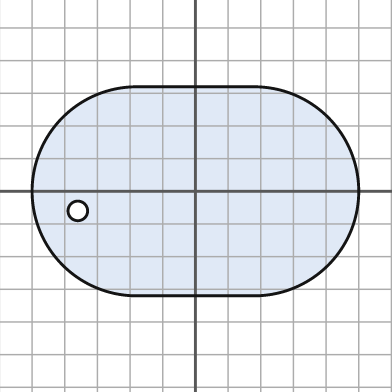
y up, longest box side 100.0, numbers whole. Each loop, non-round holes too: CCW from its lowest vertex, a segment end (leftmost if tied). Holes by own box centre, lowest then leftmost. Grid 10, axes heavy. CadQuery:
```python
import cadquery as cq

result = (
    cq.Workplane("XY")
    .moveTo(-18.0, -32.0)
    .lineTo(18.0, -32.0)
    .threePointArc((50.0, 0.0), (18.0, 32.0))
    .lineTo(-18.0, 32.0)
    .threePointArc((-50.0, 0.0), (-18.0, -32.0))
    .close()
    .moveTo(-36.0, -6.0)
    .circle(3.0)
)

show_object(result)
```